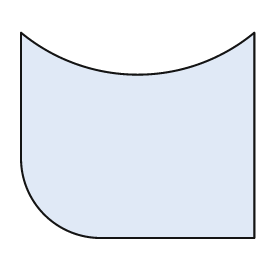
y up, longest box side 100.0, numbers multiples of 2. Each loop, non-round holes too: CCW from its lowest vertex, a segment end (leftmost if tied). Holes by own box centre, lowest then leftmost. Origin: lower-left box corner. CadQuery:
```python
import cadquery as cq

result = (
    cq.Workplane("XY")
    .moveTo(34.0, 0.0)
    .lineTo(100.0, 0.0)
    .lineTo(100.0, 88.0)
    .threePointArc((50.0, 70.0), (0.0, 88.0))
    .lineTo(0.0, 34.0)
    .threePointArc((10.0, 10.0), (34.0, 0.0))
    .close()
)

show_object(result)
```